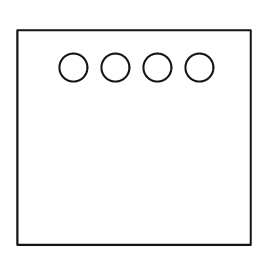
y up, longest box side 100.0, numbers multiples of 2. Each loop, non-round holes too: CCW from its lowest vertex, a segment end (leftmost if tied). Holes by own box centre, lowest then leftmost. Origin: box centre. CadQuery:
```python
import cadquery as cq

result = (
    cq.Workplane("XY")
    .moveTo(-50.0, -46.0)
    .lineTo(50.0, -46.0)
    .lineTo(50.0, 46.0)
    .lineTo(-50.0, 46.0)
    .close()
    .moveTo(-26.0, 30.0)
    .circle(6.0)
    .moveTo(-8.0, 30.0)
    .circle(6.0)
    .moveTo(10.0, 30.0)
    .circle(6.0)
    .moveTo(28.0, 30.0)
    .circle(6.0)
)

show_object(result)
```